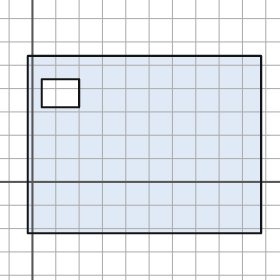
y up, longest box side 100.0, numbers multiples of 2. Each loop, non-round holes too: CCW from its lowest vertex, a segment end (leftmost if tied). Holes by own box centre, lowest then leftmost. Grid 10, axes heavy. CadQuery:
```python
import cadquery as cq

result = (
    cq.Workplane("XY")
    .moveTo(-2.0, -22.0)
    .lineTo(98.0, -22.0)
    .lineTo(98.0, 54.0)
    .lineTo(-2.0, 54.0)
    .close()
    .moveTo(4.0, 32.0)
    .lineTo(20.0, 32.0)
    .lineTo(20.0, 44.0)
    .lineTo(4.0, 44.0)
    .close()
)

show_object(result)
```